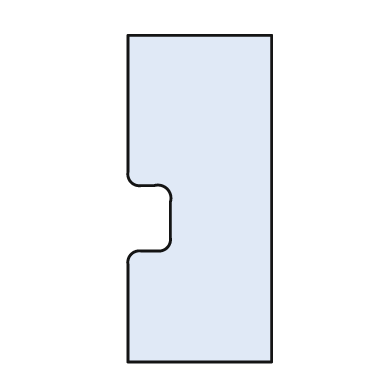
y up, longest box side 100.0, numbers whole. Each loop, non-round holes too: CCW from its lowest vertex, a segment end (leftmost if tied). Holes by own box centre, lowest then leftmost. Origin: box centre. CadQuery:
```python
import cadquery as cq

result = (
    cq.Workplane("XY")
    .moveTo(-22.0, -50.0)
    .lineTo(22.0, -50.0)
    .lineTo(22.0, 50.0)
    .lineTo(-22.0, 50.0)
    .lineTo(-22.0, 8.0)
    .threePointArc((-21.0, 5.0), (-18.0, 4.0))
    .lineTo(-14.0, 4.0)
    .threePointArc((-10.0, 3.0), (-9.0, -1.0))
    .lineTo(-9.0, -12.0)
    .threePointArc((-10.0, -15.0), (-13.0, -16.0))
    .lineTo(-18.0, -16.0)
    .threePointArc((-21.0, -17.0), (-22.0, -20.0))
    .close()
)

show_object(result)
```